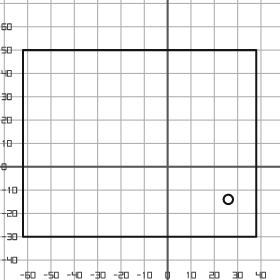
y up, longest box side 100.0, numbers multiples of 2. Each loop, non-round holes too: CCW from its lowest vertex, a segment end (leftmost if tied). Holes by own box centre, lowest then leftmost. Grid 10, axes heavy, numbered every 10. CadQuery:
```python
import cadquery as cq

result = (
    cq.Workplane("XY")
    .moveTo(-62.0, -30.0)
    .lineTo(38.0, -30.0)
    .lineTo(38.0, 50.0)
    .lineTo(-62.0, 50.0)
    .close()
    .moveTo(26.0, -14.0)
    .circle(2.0)
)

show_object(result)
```